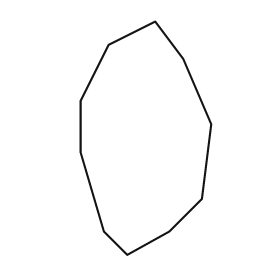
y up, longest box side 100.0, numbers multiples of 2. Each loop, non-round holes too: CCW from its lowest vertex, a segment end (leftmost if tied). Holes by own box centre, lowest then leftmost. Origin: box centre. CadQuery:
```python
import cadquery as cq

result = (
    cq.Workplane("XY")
    .moveTo(-8.0, -50.0)
    .lineTo(10.0, -40.0)
    .lineTo(24.0, -26.0)
    .lineTo(28.0, 6.0)
    .lineTo(16.0, 34.0)
    .lineTo(4.0, 50.0)
    .lineTo(-16.0, 40.0)
    .lineTo(-28.0, 16.0)
    .lineTo(-28.0, -6.0)
    .lineTo(-18.0, -40.0)
    .close()
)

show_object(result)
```